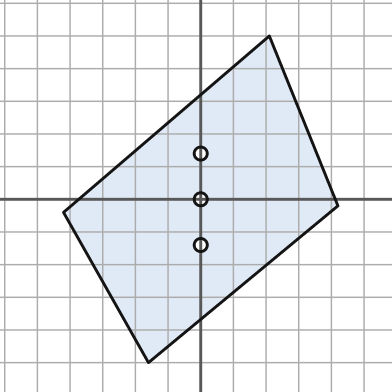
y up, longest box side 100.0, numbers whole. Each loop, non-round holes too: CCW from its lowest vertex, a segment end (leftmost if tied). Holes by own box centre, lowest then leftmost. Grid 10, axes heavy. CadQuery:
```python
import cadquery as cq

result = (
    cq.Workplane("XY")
    .moveTo(-16.0, -50.0)
    .lineTo(42.0, -2.0)
    .lineTo(21.0, 50.0)
    .lineTo(-42.0, -4.0)
    .close()
    .moveTo(0.0, -14.0)
    .circle(2.0)
    .moveTo(0.0, 0.0)
    .circle(2.0)
    .moveTo(0.0, 14.0)
    .circle(2.0)
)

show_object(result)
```